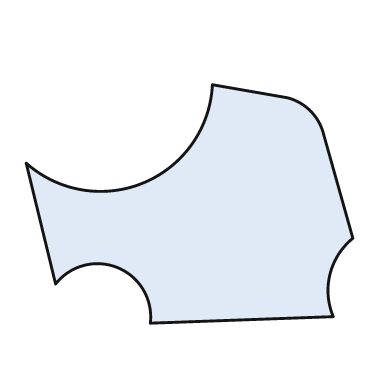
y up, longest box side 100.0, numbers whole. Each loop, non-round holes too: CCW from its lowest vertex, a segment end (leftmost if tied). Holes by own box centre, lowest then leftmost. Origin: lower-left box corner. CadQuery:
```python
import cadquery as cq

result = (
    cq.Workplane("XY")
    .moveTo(38.0, 0.0)
    .lineTo(94.0, 2.0)
    .threePointArc((93.0, 15.0), (100.0, 26.0))
    .lineTo(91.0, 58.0)
    .threePointArc((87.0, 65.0), (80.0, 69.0))
    .lineTo(57.0, 73.0)
    .threePointArc((36.0, 43.0), (0.0, 49.0))
    .lineTo(9.0, 12.0)
    .threePointArc((28.0, 17.0), (38.0, 0.0))
    .close()
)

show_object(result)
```